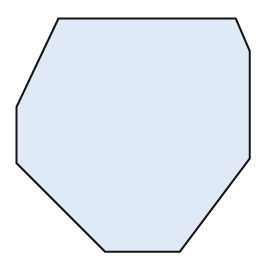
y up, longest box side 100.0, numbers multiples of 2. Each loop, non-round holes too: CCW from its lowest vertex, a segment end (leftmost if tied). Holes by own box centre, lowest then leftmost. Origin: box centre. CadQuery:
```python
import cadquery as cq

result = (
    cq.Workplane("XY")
    .moveTo(-12.0, -50.0)
    .lineTo(20.0, -50.0)
    .lineTo(50.0, -10.0)
    .lineTo(50.0, 36.0)
    .lineTo(44.0, 50.0)
    .lineTo(-32.0, 50.0)
    .lineTo(-50.0, 12.0)
    .lineTo(-50.0, -12.0)
    .close()
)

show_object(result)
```